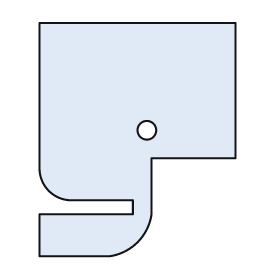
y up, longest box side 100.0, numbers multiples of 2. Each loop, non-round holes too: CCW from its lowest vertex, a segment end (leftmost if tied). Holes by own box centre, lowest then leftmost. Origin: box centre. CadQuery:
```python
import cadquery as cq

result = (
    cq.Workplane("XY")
    .moveTo(-42.0, -50.0)
    .lineTo(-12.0, -50.0)
    .threePointArc((0.0, -44.0), (6.0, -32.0))
    .lineTo(6.0, -8.0)
    .lineTo(42.0, -8.0)
    .lineTo(42.0, 50.0)
    .lineTo(-42.0, 50.0)
    .lineTo(-42.0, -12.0)
    .threePointArc((-38.0, -22.0), (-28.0, -26.0))
    .lineTo(-2.0, -26.0)
    .lineTo(-2.0, -32.0)
    .lineTo(-42.0, -32.0)
    .close()
    .moveTo(4.0, 4.0)
    .circle(4.0)
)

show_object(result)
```